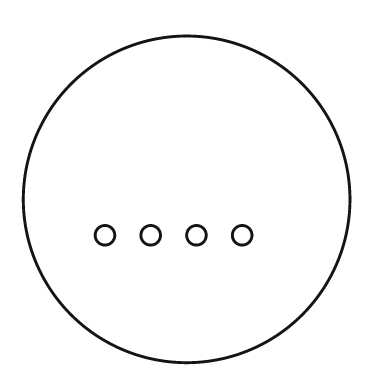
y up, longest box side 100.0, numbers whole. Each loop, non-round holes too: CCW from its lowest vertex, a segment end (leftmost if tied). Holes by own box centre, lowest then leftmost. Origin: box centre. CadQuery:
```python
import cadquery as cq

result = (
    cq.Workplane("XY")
    .moveTo(0.0, 0.0)
    .circle(50.0)
    .moveTo(-25.0, -11.0)
    .circle(3.0)
    .moveTo(-11.0, -11.0)
    .circle(3.0)
    .moveTo(3.0, -11.0)
    .circle(3.0)
    .moveTo(17.0, -11.0)
    .circle(3.0)
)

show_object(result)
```